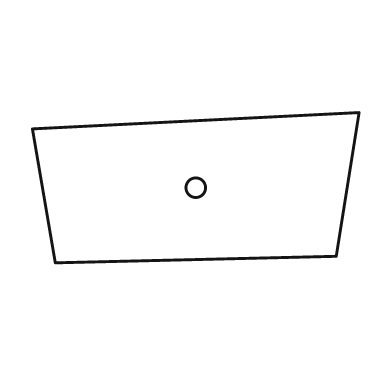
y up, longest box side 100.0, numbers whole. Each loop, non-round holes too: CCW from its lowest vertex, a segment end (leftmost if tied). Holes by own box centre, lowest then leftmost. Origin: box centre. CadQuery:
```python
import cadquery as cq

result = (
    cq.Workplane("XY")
    .moveTo(-43.0, -23.0)
    .lineTo(43.0, -21.0)
    .lineTo(50.0, 23.0)
    .lineTo(-50.0, 18.0)
    .close()
    .moveTo(0.0, 0.0)
    .circle(3.0)
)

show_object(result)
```